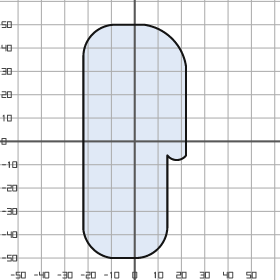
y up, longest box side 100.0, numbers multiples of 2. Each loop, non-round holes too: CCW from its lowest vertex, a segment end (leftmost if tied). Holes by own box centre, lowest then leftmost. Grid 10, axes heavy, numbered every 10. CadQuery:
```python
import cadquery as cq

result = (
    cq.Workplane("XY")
    .moveTo(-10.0, -50.0)
    .lineTo(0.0, -50.0)
    .threePointArc((10.0, -46.0), (14.0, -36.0))
    .lineTo(14.0, -6.0)
    .threePointArc((18.0, -8.0), (22.0, -6.0))
    .lineTo(22.0, 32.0)
    .threePointArc((16.0, 44.0), (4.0, 50.0))
    .lineTo(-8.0, 50.0)
    .threePointArc((-18.0, 46.0), (-22.0, 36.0))
    .lineTo(-22.0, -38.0)
    .threePointArc((-18.0, -46.0), (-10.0, -50.0))
    .close()
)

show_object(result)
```